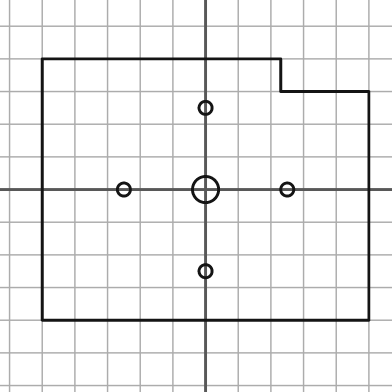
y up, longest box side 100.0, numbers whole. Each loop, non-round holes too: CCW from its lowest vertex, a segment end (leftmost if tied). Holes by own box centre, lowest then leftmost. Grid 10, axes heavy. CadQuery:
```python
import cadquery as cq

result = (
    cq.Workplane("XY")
    .moveTo(-50.0, -40.0)
    .lineTo(50.0, -40.0)
    .lineTo(50.0, 30.0)
    .lineTo(23.0, 30.0)
    .lineTo(23.0, 40.0)
    .lineTo(-50.0, 40.0)
    .close()
    .moveTo(0.0, -25.0)
    .circle(2.0)
    .moveTo(-25.0, 0.0)
    .circle(2.0)
    .moveTo(0.0, 0.0)
    .circle(4.0)
    .moveTo(25.0, 0.0)
    .circle(2.0)
    .moveTo(0.0, 25.0)
    .circle(2.0)
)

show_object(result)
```